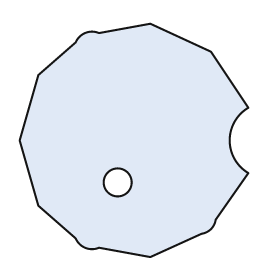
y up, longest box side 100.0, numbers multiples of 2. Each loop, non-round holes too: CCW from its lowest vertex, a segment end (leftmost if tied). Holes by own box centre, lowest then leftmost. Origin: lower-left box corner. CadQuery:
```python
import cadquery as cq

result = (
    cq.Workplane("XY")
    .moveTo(56.0, 0.0)
    .lineTo(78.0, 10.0)
    .threePointArc((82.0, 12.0), (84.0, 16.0))
    .lineTo(98.0, 36.0)
    .threePointArc((90.0, 50.0), (98.0, 64.0))
    .lineTo(82.0, 88.0)
    .lineTo(56.0, 100.0)
    .lineTo(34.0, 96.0)
    .threePointArc((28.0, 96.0), (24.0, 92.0))
    .lineTo(8.0, 78.0)
    .lineTo(0.0, 50.0)
    .lineTo(8.0, 22.0)
    .lineTo(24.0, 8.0)
    .threePointArc((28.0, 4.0), (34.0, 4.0))
    .close()
    .moveTo(42.0, 32.0)
    .circle(6.0)
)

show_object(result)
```